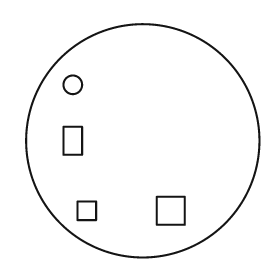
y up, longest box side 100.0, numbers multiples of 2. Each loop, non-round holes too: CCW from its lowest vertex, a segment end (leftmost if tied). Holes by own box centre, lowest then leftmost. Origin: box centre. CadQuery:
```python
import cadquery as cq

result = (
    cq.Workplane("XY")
    .moveTo(0.0, 0.0)
    .circle(50.0)
    .moveTo(-28.0, -34.0)
    .lineTo(-20.0, -34.0)
    .lineTo(-20.0, -26.0)
    .lineTo(-28.0, -26.0)
    .close()
    .moveTo(6.0, -36.0)
    .lineTo(18.0, -36.0)
    .lineTo(18.0, -24.0)
    .lineTo(6.0, -24.0)
    .close()
    .moveTo(-34.0, -6.0)
    .lineTo(-26.0, -6.0)
    .lineTo(-26.0, 6.0)
    .lineTo(-34.0, 6.0)
    .close()
    .moveTo(-30.0, 24.0)
    .circle(4.0)
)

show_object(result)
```